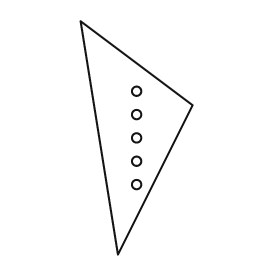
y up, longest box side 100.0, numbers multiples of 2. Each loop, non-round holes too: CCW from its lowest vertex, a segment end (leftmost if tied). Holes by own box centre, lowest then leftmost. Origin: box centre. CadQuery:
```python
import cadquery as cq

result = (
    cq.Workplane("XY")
    .moveTo(-8.0, -50.0)
    .lineTo(24.0, 14.0)
    .lineTo(-24.0, 50.0)
    .close()
    .moveTo(0.0, -20.0)
    .circle(2.0)
    .moveTo(0.0, -10.0)
    .circle(2.0)
    .moveTo(0.0, 0.0)
    .circle(2.0)
    .moveTo(0.0, 10.0)
    .circle(2.0)
    .moveTo(0.0, 20.0)
    .circle(2.0)
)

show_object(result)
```